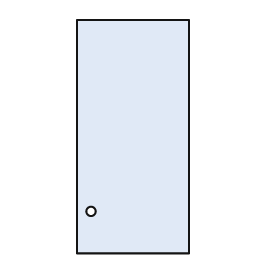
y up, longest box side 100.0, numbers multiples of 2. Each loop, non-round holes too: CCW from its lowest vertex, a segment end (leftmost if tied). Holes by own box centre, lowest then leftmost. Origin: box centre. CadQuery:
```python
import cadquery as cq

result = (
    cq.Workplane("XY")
    .moveTo(-24.0, -50.0)
    .lineTo(24.0, -50.0)
    .lineTo(24.0, 50.0)
    .lineTo(-24.0, 50.0)
    .close()
    .moveTo(-18.0, -32.0)
    .circle(2.0)
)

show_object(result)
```